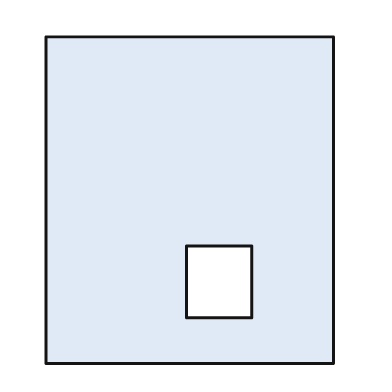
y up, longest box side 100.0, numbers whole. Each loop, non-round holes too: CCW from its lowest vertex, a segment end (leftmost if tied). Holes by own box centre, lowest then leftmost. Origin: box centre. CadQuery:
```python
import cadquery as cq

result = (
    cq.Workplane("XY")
    .moveTo(-44.0, -50.0)
    .lineTo(44.0, -50.0)
    .lineTo(44.0, 50.0)
    .lineTo(-44.0, 50.0)
    .close()
    .moveTo(-1.0, -36.0)
    .lineTo(19.0, -36.0)
    .lineTo(19.0, -14.0)
    .lineTo(-1.0, -14.0)
    .close()
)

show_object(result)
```